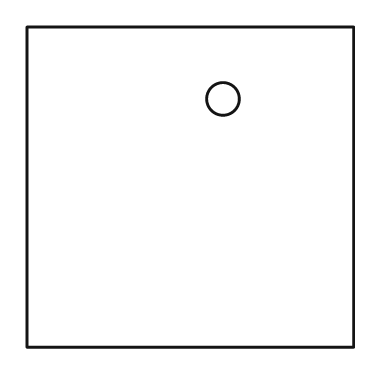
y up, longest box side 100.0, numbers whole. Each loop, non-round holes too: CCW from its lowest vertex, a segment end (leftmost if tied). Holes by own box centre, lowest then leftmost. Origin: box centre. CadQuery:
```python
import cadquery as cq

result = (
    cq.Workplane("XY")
    .moveTo(-50.0, -49.0)
    .lineTo(50.0, -49.0)
    .lineTo(50.0, 49.0)
    .lineTo(-50.0, 49.0)
    .close()
    .moveTo(10.0, 27.0)
    .circle(5.0)
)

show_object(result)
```